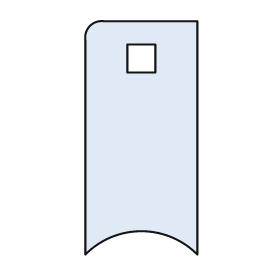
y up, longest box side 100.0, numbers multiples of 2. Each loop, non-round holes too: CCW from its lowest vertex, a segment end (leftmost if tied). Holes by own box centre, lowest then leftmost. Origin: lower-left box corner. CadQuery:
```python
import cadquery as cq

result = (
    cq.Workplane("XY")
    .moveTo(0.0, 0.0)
    .threePointArc((24.0, 10.0), (48.0, 0.0))
    .lineTo(48.0, 100.0)
    .lineTo(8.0, 100.0)
    .threePointArc((2.0, 98.0), (0.0, 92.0))
    .close()
    .moveTo(18.0, 78.0)
    .lineTo(30.0, 78.0)
    .lineTo(30.0, 90.0)
    .lineTo(18.0, 90.0)
    .close()
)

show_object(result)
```